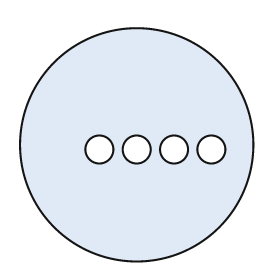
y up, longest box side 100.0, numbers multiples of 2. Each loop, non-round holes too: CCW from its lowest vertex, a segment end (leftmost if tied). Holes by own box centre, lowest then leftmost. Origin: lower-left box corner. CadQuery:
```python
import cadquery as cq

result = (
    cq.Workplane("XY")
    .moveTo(50.0, 50.0)
    .circle(50.0)
    .moveTo(34.0, 48.0)
    .circle(6.0)
    .moveTo(50.0, 48.0)
    .circle(6.0)
    .moveTo(66.0, 48.0)
    .circle(6.0)
    .moveTo(82.0, 48.0)
    .circle(6.0)
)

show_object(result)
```